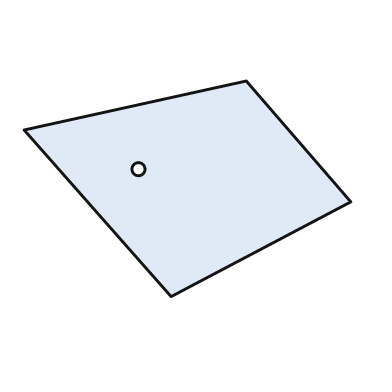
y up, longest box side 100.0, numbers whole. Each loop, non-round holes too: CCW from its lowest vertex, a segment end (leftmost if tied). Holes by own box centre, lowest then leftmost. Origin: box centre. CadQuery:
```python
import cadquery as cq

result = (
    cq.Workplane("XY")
    .moveTo(-5.0, -33.0)
    .lineTo(50.0, -4.0)
    .lineTo(18.0, 33.0)
    .lineTo(-50.0, 18.0)
    .close()
    .moveTo(-15.0, 6.0)
    .circle(2.0)
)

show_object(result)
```